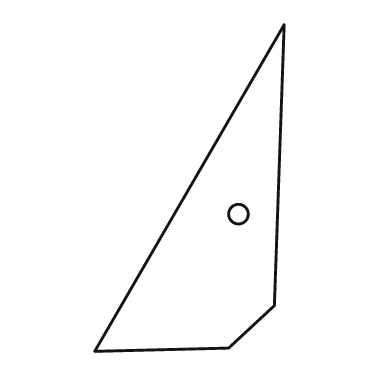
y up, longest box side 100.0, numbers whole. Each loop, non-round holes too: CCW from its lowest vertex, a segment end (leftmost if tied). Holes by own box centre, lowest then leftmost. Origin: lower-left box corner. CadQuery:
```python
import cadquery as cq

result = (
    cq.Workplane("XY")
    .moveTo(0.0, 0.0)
    .lineTo(41.0, 1.0)
    .lineTo(55.0, 14.0)
    .lineTo(58.0, 100.0)
    .close()
    .moveTo(44.0, 42.0)
    .circle(3.0)
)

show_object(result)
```